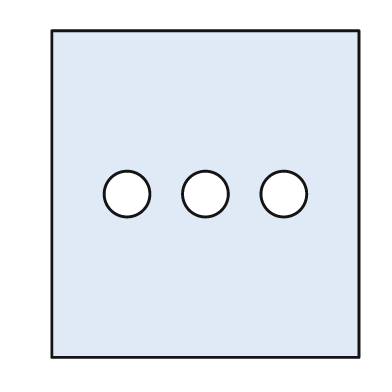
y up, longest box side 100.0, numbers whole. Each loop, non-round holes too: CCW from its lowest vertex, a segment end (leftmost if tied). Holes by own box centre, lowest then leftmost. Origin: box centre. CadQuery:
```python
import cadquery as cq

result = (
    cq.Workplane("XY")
    .moveTo(-47.0, -50.0)
    .lineTo(47.0, -50.0)
    .lineTo(47.0, 50.0)
    .lineTo(-47.0, 50.0)
    .close()
    .moveTo(-24.0, 0.0)
    .circle(7.0)
    .moveTo(0.0, 0.0)
    .circle(7.0)
    .moveTo(24.0, 0.0)
    .circle(7.0)
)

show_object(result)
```